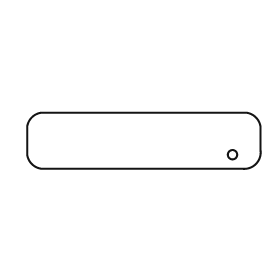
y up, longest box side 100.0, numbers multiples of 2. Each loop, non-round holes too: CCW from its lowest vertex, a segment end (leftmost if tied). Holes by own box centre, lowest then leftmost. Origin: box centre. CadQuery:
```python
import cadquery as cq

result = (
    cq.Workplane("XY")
    .moveTo(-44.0, -12.0)
    .lineTo(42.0, -12.0)
    .threePointArc((48.0, -10.0), (50.0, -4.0))
    .lineTo(50.0, 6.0)
    .threePointArc((48.0, 10.0), (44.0, 12.0))
    .lineTo(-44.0, 12.0)
    .threePointArc((-48.0, 10.0), (-50.0, 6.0))
    .lineTo(-50.0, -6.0)
    .threePointArc((-48.0, -10.0), (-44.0, -12.0))
    .close()
    .moveTo(38.0, -6.0)
    .circle(2.0)
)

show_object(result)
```